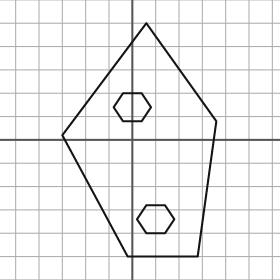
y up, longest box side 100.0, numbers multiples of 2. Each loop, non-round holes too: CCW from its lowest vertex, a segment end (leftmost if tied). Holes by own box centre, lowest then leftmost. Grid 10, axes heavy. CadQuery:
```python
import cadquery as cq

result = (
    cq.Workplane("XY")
    .moveTo(-2.0, -50.0)
    .lineTo(28.0, -50.0)
    .lineTo(36.0, 8.0)
    .lineTo(6.0, 50.0)
    .lineTo(-30.0, 2.0)
    .close()
    .moveTo(6.0, -40.0)
    .lineTo(14.0, -40.0)
    .lineTo(18.0, -34.0)
    .lineTo(14.0, -28.0)
    .lineTo(6.0, -28.0)
    .lineTo(2.0, -34.0)
    .close()
    .moveTo(-4.0, 8.0)
    .lineTo(4.0, 8.0)
    .lineTo(8.0, 14.0)
    .lineTo(4.0, 20.0)
    .lineTo(-4.0, 20.0)
    .lineTo(-8.0, 14.0)
    .close()
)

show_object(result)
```